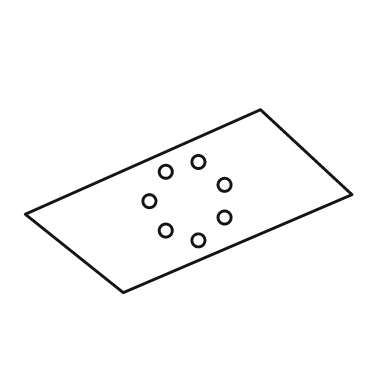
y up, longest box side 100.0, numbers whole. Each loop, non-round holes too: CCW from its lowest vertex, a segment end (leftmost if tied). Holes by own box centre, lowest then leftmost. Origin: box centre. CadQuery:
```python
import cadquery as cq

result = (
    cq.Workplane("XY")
    .moveTo(-20.0, -28.0)
    .lineTo(50.0, 2.0)
    .lineTo(22.0, 28.0)
    .lineTo(-50.0, -4.0)
    .close()
    .moveTo(3.0, -12.0)
    .circle(2.0)
    .moveTo(-7.0, -9.0)
    .circle(2.0)
    .moveTo(11.0, -5.0)
    .circle(2.0)
    .moveTo(-12.0, 0.0)
    .circle(2.0)
    .moveTo(11.0, 5.0)
    .circle(2.0)
    .moveTo(-7.0, 9.0)
    .circle(2.0)
    .moveTo(3.0, 12.0)
    .circle(2.0)
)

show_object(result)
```